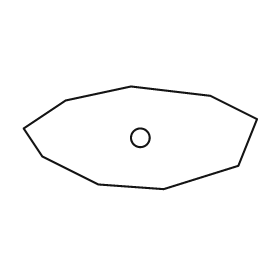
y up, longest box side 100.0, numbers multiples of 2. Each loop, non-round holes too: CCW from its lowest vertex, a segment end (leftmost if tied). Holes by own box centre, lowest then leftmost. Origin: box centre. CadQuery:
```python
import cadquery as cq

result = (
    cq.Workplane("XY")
    .moveTo(10.0, -22.0)
    .lineTo(42.0, -12.0)
    .lineTo(50.0, 8.0)
    .lineTo(30.0, 18.0)
    .lineTo(-4.0, 22.0)
    .lineTo(-32.0, 16.0)
    .lineTo(-50.0, 4.0)
    .lineTo(-42.0, -8.0)
    .lineTo(-18.0, -20.0)
    .close()
    .moveTo(0.0, 0.0)
    .circle(4.0)
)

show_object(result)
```